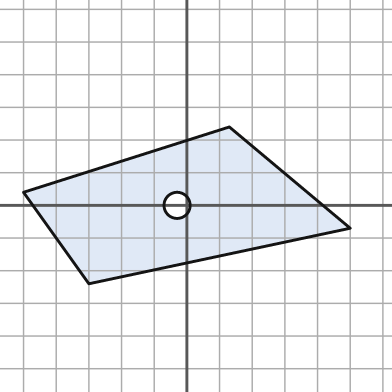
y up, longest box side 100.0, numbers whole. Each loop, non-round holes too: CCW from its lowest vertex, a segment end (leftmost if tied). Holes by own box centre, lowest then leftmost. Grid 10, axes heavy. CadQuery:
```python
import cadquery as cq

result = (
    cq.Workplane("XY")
    .moveTo(-30.0, -24.0)
    .lineTo(50.0, -7.0)
    .lineTo(13.0, 24.0)
    .lineTo(-50.0, 4.0)
    .close()
    .moveTo(-3.0, 0.0)
    .circle(4.0)
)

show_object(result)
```